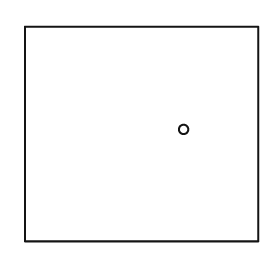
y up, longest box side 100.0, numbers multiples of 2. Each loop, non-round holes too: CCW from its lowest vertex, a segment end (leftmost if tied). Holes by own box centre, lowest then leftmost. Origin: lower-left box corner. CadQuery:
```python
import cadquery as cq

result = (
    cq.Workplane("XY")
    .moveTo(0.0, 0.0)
    .lineTo(100.0, 0.0)
    .lineTo(100.0, 92.0)
    .lineTo(0.0, 92.0)
    .close()
    .moveTo(68.0, 48.0)
    .circle(2.0)
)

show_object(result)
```